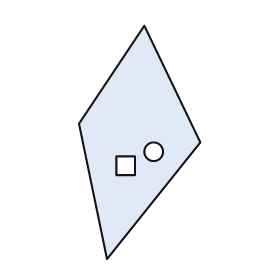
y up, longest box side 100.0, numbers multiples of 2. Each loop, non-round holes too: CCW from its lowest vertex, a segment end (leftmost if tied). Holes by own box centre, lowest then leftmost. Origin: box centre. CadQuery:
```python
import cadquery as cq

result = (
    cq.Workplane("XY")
    .moveTo(-14.0, -50.0)
    .lineTo(26.0, 0.0)
    .lineTo(2.0, 50.0)
    .lineTo(-26.0, 8.0)
    .close()
    .moveTo(-10.0, -14.0)
    .lineTo(-2.0, -14.0)
    .lineTo(-2.0, -6.0)
    .lineTo(-10.0, -6.0)
    .close()
    .moveTo(6.0, -4.0)
    .circle(4.0)
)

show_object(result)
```